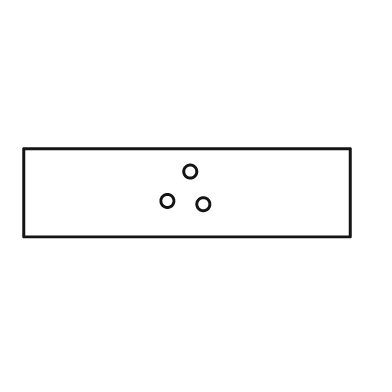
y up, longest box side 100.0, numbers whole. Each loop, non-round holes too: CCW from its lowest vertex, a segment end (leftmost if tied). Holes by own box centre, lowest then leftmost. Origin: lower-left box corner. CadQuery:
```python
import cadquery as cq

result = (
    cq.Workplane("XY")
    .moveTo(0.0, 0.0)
    .lineTo(100.0, 0.0)
    .lineTo(100.0, 27.0)
    .lineTo(0.0, 27.0)
    .close()
    .moveTo(55.0, 10.0)
    .circle(2.0)
    .moveTo(44.0, 11.0)
    .circle(2.0)
    .moveTo(51.0, 20.0)
    .circle(2.0)
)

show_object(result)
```